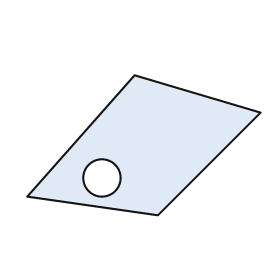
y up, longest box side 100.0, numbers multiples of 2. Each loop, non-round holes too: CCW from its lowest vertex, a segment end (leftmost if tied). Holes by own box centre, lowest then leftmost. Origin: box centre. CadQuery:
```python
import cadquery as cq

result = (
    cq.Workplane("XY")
    .moveTo(6.0, -30.0)
    .lineTo(50.0, 14.0)
    .lineTo(-4.0, 30.0)
    .lineTo(-50.0, -22.0)
    .close()
    .moveTo(-18.0, -14.0)
    .circle(8.0)
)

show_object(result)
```